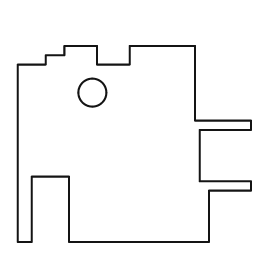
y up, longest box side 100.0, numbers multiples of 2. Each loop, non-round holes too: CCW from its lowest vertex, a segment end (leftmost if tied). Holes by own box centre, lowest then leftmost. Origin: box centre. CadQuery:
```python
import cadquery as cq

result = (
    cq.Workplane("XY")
    .moveTo(-50.0, -42.0)
    .lineTo(-44.0, -42.0)
    .lineTo(-44.0, -14.0)
    .lineTo(-28.0, -14.0)
    .lineTo(-28.0, -42.0)
    .lineTo(32.0, -42.0)
    .lineTo(32.0, -20.0)
    .lineTo(50.0, -20.0)
    .lineTo(50.0, -16.0)
    .lineTo(28.0, -16.0)
    .lineTo(28.0, 6.0)
    .lineTo(50.0, 6.0)
    .lineTo(50.0, 10.0)
    .lineTo(26.0, 10.0)
    .lineTo(26.0, 42.0)
    .lineTo(-2.0, 42.0)
    .lineTo(-2.0, 34.0)
    .lineTo(-16.0, 34.0)
    .lineTo(-16.0, 42.0)
    .lineTo(-30.0, 42.0)
    .lineTo(-30.0, 38.0)
    .lineTo(-38.0, 38.0)
    .lineTo(-38.0, 34.0)
    .lineTo(-50.0, 34.0)
    .close()
    .moveTo(-18.0, 22.0)
    .circle(6.0)
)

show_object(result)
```